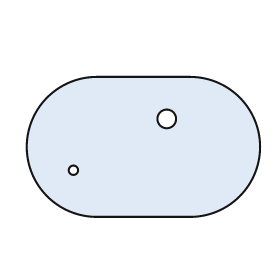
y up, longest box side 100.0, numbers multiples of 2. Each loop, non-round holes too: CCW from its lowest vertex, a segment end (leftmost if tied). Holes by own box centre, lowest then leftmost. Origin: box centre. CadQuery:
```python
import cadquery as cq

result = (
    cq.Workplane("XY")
    .moveTo(-20.0, -30.0)
    .lineTo(20.0, -30.0)
    .threePointArc((50.0, 0.0), (20.0, 30.0))
    .lineTo(-20.0, 30.0)
    .threePointArc((-50.0, 0.0), (-20.0, -30.0))
    .close()
    .moveTo(-30.0, -10.0)
    .circle(2.0)
    .moveTo(10.0, 12.0)
    .circle(4.0)
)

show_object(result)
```